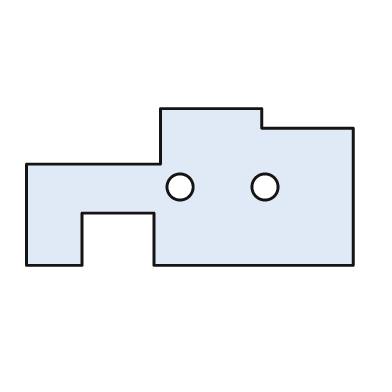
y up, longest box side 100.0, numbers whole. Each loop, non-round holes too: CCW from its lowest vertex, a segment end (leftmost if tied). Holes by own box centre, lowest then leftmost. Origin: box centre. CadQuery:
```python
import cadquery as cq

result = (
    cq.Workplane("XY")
    .moveTo(-50.0, -24.0)
    .lineTo(-33.0, -24.0)
    .lineTo(-33.0, -8.0)
    .lineTo(-11.0, -8.0)
    .lineTo(-11.0, -24.0)
    .lineTo(50.0, -24.0)
    .lineTo(50.0, 18.0)
    .lineTo(22.0, 18.0)
    .lineTo(22.0, 24.0)
    .lineTo(-9.0, 24.0)
    .lineTo(-9.0, 7.0)
    .lineTo(-50.0, 7.0)
    .close()
    .moveTo(-3.0, 0.0)
    .circle(4.0)
    .moveTo(23.0, 0.0)
    .circle(4.0)
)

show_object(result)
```